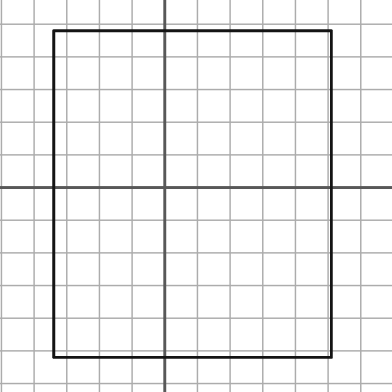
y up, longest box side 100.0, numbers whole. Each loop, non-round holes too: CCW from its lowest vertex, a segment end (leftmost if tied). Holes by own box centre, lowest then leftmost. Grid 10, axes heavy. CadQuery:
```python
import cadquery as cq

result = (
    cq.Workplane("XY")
    .moveTo(-34.0, -52.0)
    .lineTo(51.0, -52.0)
    .lineTo(51.0, 48.0)
    .lineTo(-34.0, 48.0)
    .close()
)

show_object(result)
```